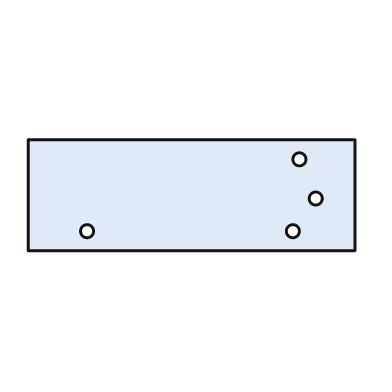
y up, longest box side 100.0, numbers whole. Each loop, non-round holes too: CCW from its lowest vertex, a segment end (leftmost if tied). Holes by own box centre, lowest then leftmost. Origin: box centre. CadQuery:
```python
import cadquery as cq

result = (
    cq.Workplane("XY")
    .moveTo(-50.0, -17.0)
    .lineTo(50.0, -17.0)
    .lineTo(50.0, 17.0)
    .lineTo(-50.0, 17.0)
    .close()
    .moveTo(-32.0, -11.0)
    .circle(2.0)
    .moveTo(31.0, -11.0)
    .circle(2.0)
    .moveTo(38.0, -1.0)
    .circle(2.0)
    .moveTo(33.0, 11.0)
    .circle(2.0)
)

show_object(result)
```